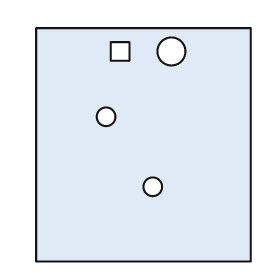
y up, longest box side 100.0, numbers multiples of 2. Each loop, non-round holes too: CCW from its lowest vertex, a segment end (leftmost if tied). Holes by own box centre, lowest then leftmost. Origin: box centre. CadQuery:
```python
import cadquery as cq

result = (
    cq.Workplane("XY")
    .moveTo(-46.0, -50.0)
    .lineTo(46.0, -50.0)
    .lineTo(46.0, 50.0)
    .lineTo(-46.0, 50.0)
    .close()
    .moveTo(4.0, -18.0)
    .circle(4.0)
    .moveTo(-16.0, 12.0)
    .circle(4.0)
    .moveTo(-14.0, 36.0)
    .lineTo(-6.0, 36.0)
    .lineTo(-6.0, 44.0)
    .lineTo(-14.0, 44.0)
    .close()
    .moveTo(12.0, 40.0)
    .circle(6.0)
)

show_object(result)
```